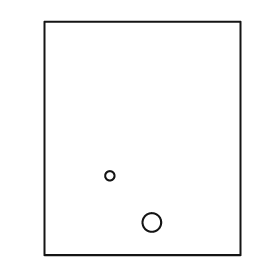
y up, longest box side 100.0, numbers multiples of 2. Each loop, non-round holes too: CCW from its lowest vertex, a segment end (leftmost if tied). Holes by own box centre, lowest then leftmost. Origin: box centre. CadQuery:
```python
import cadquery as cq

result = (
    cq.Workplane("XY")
    .moveTo(-42.0, -50.0)
    .lineTo(42.0, -50.0)
    .lineTo(42.0, 50.0)
    .lineTo(-42.0, 50.0)
    .close()
    .moveTo(4.0, -36.0)
    .circle(4.0)
    .moveTo(-14.0, -16.0)
    .circle(2.0)
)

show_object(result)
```